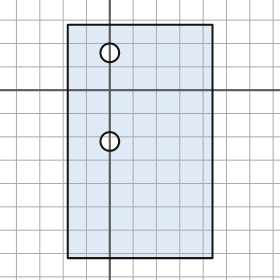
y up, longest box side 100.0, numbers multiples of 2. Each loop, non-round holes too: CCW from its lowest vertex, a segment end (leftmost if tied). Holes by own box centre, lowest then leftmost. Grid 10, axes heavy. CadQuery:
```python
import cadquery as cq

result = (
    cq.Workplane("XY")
    .moveTo(-18.0, -72.0)
    .lineTo(44.0, -72.0)
    .lineTo(44.0, 28.0)
    .lineTo(-18.0, 28.0)
    .close()
    .moveTo(0.0, -22.0)
    .circle(4.0)
    .moveTo(0.0, 16.0)
    .circle(4.0)
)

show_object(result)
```